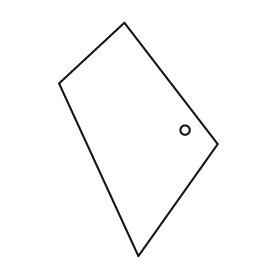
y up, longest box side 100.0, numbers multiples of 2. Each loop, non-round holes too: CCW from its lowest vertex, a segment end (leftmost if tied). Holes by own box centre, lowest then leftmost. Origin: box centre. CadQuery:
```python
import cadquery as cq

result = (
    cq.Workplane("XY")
    .moveTo(0.0, -50.0)
    .lineTo(34.0, -2.0)
    .lineTo(-6.0, 50.0)
    .lineTo(-34.0, 24.0)
    .close()
    .moveTo(20.0, 4.0)
    .circle(2.0)
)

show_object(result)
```